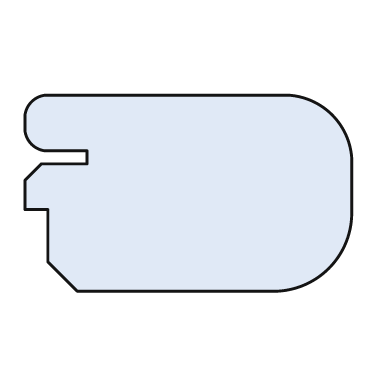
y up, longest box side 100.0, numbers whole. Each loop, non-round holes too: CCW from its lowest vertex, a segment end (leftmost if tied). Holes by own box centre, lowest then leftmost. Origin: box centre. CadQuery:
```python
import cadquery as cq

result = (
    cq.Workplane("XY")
    .moveTo(-34.0, -30.0)
    .lineTo(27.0, -30.0)
    .threePointArc((43.0, -23.0), (50.0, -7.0))
    .lineTo(50.0, 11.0)
    .threePointArc((44.0, 24.0), (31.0, 30.0))
    .lineTo(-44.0, 30.0)
    .threePointArc((-48.0, 28.0), (-50.0, 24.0))
    .lineTo(-50.0, 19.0)
    .threePointArc((-48.0, 15.0), (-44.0, 13.0))
    .lineTo(-31.0, 13.0)
    .lineTo(-31.0, 9.0)
    .lineTo(-45.0, 9.0)
    .lineTo(-50.0, 4.0)
    .lineTo(-50.0, -5.0)
    .lineTo(-43.0, -5.0)
    .lineTo(-43.0, -21.0)
    .close()
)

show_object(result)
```